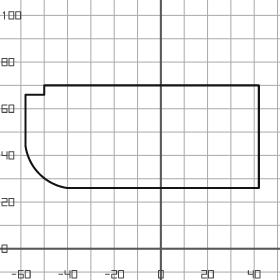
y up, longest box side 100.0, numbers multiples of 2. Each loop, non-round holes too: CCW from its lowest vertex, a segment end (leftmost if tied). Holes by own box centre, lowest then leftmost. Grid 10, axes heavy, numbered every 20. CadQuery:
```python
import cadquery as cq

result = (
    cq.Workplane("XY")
    .moveTo(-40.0, 26.0)
    .lineTo(42.0, 26.0)
    .lineTo(42.0, 70.0)
    .lineTo(-50.0, 70.0)
    .lineTo(-50.0, 66.0)
    .lineTo(-58.0, 66.0)
    .lineTo(-58.0, 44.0)
    .threePointArc((-52.0, 32.0), (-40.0, 26.0))
    .close()
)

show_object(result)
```